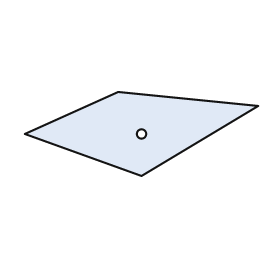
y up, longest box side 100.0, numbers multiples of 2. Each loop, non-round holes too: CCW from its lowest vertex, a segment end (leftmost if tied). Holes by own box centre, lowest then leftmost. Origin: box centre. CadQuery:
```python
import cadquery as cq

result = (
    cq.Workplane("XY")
    .moveTo(0.0, -18.0)
    .lineTo(50.0, 12.0)
    .lineTo(-10.0, 18.0)
    .lineTo(-50.0, 0.0)
    .close()
    .moveTo(0.0, 0.0)
    .circle(2.0)
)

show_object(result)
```